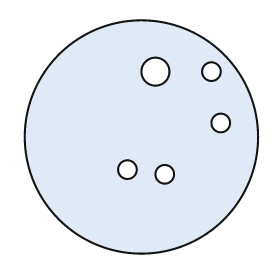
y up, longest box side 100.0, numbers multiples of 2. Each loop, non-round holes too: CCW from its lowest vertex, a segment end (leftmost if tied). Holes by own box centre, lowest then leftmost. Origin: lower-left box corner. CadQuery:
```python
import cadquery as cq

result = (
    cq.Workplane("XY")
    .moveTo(50.0, 50.0)
    .circle(50.0)
    .moveTo(60.0, 34.0)
    .circle(4.0)
    .moveTo(44.0, 36.0)
    .circle(4.0)
    .moveTo(84.0, 56.0)
    .circle(4.0)
    .moveTo(56.0, 78.0)
    .circle(6.0)
    .moveTo(80.0, 78.0)
    .circle(4.0)
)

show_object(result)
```